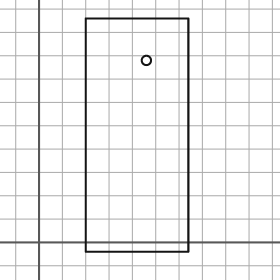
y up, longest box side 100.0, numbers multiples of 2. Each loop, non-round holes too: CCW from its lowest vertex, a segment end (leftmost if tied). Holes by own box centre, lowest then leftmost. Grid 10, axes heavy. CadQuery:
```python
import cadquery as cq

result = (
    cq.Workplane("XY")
    .moveTo(20.0, -4.0)
    .lineTo(64.0, -4.0)
    .lineTo(64.0, 96.0)
    .lineTo(20.0, 96.0)
    .close()
    .moveTo(46.0, 78.0)
    .circle(2.0)
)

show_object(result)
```